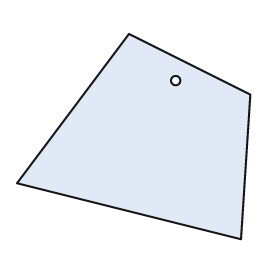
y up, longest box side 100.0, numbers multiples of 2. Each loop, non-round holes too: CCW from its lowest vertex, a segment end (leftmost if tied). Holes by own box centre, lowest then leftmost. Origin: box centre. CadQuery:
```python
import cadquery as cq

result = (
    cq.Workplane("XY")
    .moveTo(46.0, -44.0)
    .lineTo(50.0, 18.0)
    .lineTo(-2.0, 44.0)
    .lineTo(-50.0, -20.0)
    .close()
    .moveTo(18.0, 24.0)
    .circle(2.0)
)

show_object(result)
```